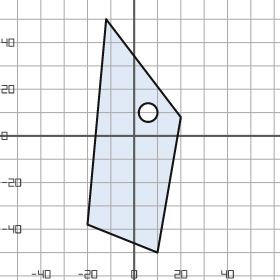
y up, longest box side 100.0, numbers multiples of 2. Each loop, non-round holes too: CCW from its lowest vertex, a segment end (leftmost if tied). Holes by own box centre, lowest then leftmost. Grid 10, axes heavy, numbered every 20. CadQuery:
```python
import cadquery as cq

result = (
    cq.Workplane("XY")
    .moveTo(10.0, -50.0)
    .lineTo(20.0, 8.0)
    .lineTo(-12.0, 50.0)
    .lineTo(-20.0, -38.0)
    .close()
    .moveTo(6.0, 10.0)
    .circle(4.0)
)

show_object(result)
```